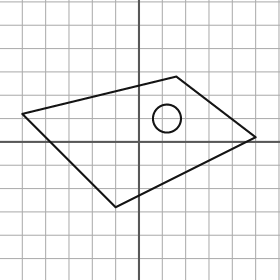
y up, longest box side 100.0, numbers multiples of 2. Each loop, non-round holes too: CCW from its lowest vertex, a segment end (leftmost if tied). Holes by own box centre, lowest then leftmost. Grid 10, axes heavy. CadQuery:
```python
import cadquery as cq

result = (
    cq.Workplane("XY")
    .moveTo(-10.0, -28.0)
    .lineTo(50.0, 2.0)
    .lineTo(16.0, 28.0)
    .lineTo(-50.0, 12.0)
    .close()
    .moveTo(12.0, 10.0)
    .circle(6.0)
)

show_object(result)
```